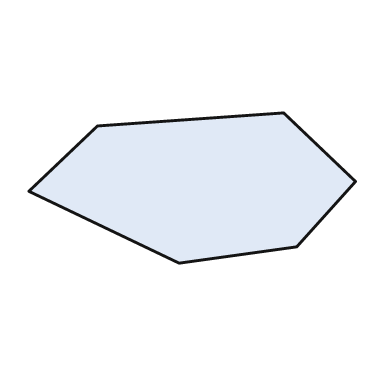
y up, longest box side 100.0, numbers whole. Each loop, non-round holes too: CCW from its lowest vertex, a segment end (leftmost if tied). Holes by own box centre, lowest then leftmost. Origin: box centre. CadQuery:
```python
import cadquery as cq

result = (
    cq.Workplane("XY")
    .moveTo(-4.0, -23.0)
    .lineTo(32.0, -18.0)
    .lineTo(50.0, 2.0)
    .lineTo(28.0, 23.0)
    .lineTo(-29.0, 19.0)
    .lineTo(-50.0, -1.0)
    .close()
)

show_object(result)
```